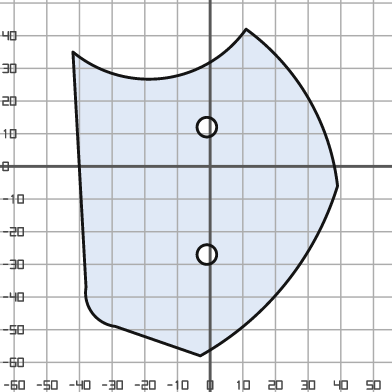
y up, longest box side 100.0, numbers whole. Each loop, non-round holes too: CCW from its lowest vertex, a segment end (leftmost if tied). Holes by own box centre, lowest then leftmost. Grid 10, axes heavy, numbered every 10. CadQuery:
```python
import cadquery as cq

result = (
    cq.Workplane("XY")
    .moveTo(-3.0, -58.0)
    .threePointArc((23.0, -36.0), (39.0, -6.0))
    .threePointArc((30.0, 21.0), (11.0, 42.0))
    .threePointArc((-14.0, 27.0), (-42.0, 35.0))
    .lineTo(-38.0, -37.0)
    .threePointArc((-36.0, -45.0), (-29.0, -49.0))
    .close()
    .moveTo(-1.0, -27.0)
    .circle(3.0)
    .moveTo(-1.0, 12.0)
    .circle(3.0)
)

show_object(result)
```